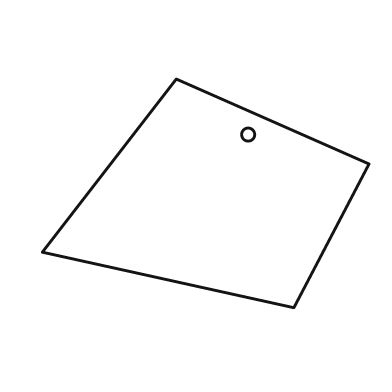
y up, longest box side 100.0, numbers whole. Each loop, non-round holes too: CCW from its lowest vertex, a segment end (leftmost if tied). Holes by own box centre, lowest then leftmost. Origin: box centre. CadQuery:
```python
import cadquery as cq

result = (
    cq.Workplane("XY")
    .moveTo(27.0, -35.0)
    .lineTo(50.0, 9.0)
    .lineTo(-9.0, 35.0)
    .lineTo(-50.0, -18.0)
    .close()
    .moveTo(13.0, 18.0)
    .circle(2.0)
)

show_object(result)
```